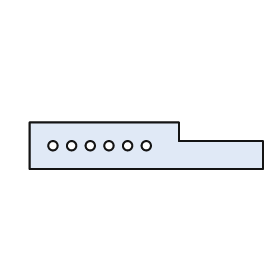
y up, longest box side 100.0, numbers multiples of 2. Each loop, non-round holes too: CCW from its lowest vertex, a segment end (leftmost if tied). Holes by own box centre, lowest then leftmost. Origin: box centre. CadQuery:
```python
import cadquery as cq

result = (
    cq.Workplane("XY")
    .moveTo(-50.0, -10.0)
    .lineTo(50.0, -10.0)
    .lineTo(50.0, 2.0)
    .lineTo(14.0, 2.0)
    .lineTo(14.0, 10.0)
    .lineTo(-50.0, 10.0)
    .close()
    .moveTo(-40.0, 0.0)
    .circle(2.0)
    .moveTo(-32.0, 0.0)
    .circle(2.0)
    .moveTo(-24.0, 0.0)
    .circle(2.0)
    .moveTo(-16.0, 0.0)
    .circle(2.0)
    .moveTo(-8.0, 0.0)
    .circle(2.0)
    .moveTo(0.0, 0.0)
    .circle(2.0)
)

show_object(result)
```